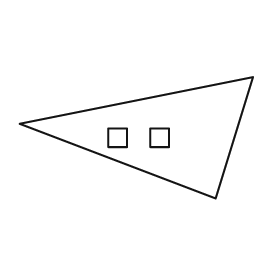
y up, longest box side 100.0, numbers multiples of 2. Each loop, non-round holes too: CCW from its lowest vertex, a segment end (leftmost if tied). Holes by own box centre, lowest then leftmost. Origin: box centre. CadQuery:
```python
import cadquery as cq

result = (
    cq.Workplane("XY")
    .moveTo(34.0, -26.0)
    .lineTo(50.0, 26.0)
    .lineTo(-50.0, 6.0)
    .close()
    .moveTo(-12.0, -4.0)
    .lineTo(-4.0, -4.0)
    .lineTo(-4.0, 4.0)
    .lineTo(-12.0, 4.0)
    .close()
    .moveTo(6.0, -4.0)
    .lineTo(14.0, -4.0)
    .lineTo(14.0, 4.0)
    .lineTo(6.0, 4.0)
    .close()
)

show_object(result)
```